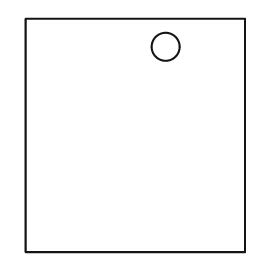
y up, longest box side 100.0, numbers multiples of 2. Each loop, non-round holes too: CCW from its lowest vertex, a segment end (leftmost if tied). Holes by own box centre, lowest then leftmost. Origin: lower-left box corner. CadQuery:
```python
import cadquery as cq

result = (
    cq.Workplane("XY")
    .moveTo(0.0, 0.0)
    .lineTo(94.0, 0.0)
    .lineTo(94.0, 100.0)
    .lineTo(0.0, 100.0)
    .close()
    .moveTo(60.0, 88.0)
    .circle(6.0)
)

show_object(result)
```